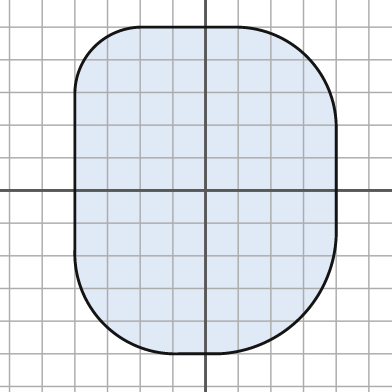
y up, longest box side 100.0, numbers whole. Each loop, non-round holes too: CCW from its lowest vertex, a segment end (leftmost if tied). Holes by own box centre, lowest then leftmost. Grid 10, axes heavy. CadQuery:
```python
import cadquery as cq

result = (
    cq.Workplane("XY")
    .moveTo(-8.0, -50.0)
    .lineTo(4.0, -50.0)
    .threePointArc((29.0, -39.0), (40.0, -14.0))
    .lineTo(40.0, 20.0)
    .threePointArc((31.0, 41.0), (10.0, 50.0))
    .lineTo(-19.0, 50.0)
    .threePointArc((-34.0, 44.0), (-40.0, 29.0))
    .lineTo(-40.0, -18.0)
    .threePointArc((-31.0, -41.0), (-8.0, -50.0))
    .close()
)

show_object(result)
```